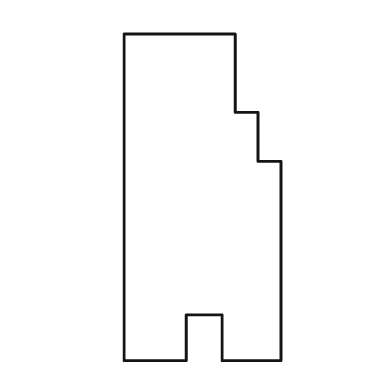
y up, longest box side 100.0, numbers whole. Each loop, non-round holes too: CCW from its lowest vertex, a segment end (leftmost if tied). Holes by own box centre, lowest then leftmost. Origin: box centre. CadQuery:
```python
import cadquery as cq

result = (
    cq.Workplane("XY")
    .moveTo(-24.0, -50.0)
    .lineTo(-5.0, -50.0)
    .lineTo(-5.0, -36.0)
    .lineTo(6.0, -36.0)
    .lineTo(6.0, -50.0)
    .lineTo(24.0, -50.0)
    .lineTo(24.0, 11.0)
    .lineTo(17.0, 11.0)
    .lineTo(17.0, 26.0)
    .lineTo(10.0, 26.0)
    .lineTo(10.0, 50.0)
    .lineTo(-24.0, 50.0)
    .close()
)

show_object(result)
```